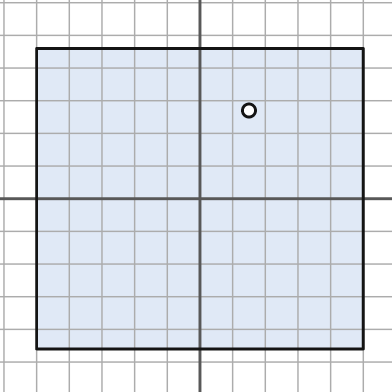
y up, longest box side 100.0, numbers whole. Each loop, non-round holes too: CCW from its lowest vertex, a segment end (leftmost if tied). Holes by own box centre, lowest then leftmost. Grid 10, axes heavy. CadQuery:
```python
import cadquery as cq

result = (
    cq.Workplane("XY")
    .moveTo(-50.0, -46.0)
    .lineTo(50.0, -46.0)
    .lineTo(50.0, 46.0)
    .lineTo(-50.0, 46.0)
    .close()
    .moveTo(15.0, 27.0)
    .circle(2.0)
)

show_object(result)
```